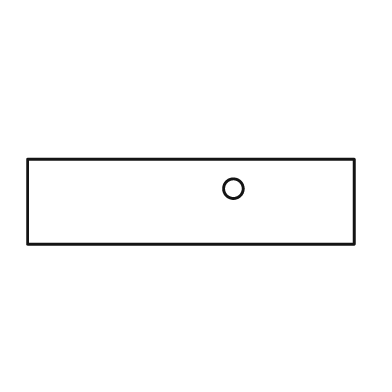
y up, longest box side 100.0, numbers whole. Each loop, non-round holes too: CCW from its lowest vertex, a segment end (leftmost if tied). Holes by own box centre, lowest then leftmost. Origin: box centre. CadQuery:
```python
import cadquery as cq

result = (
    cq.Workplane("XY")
    .moveTo(-50.0, -13.0)
    .lineTo(50.0, -13.0)
    .lineTo(50.0, 13.0)
    .lineTo(-50.0, 13.0)
    .close()
    .moveTo(13.0, 4.0)
    .circle(3.0)
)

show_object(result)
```